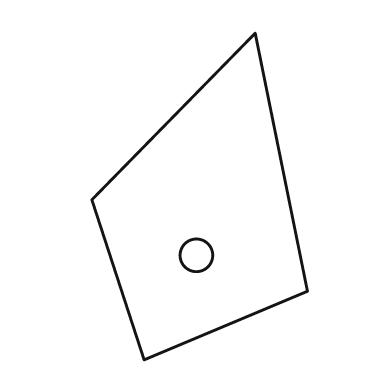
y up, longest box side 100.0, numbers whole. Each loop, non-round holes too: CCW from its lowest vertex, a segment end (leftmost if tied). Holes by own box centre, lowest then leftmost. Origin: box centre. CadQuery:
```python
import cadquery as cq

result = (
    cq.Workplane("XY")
    .moveTo(-17.0, -50.0)
    .lineTo(33.0, -29.0)
    .lineTo(17.0, 50.0)
    .lineTo(-33.0, -1.0)
    .close()
    .moveTo(-1.0, -18.0)
    .circle(5.0)
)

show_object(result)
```